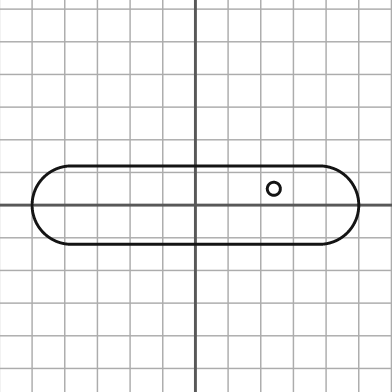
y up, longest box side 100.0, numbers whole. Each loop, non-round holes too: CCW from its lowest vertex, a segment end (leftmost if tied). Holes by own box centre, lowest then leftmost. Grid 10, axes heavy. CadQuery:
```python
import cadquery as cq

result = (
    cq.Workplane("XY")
    .moveTo(-38.0, -12.0)
    .lineTo(38.0, -12.0)
    .threePointArc((50.0, 0.0), (38.0, 12.0))
    .lineTo(-38.0, 12.0)
    .threePointArc((-50.0, 0.0), (-38.0, -12.0))
    .close()
    .moveTo(24.0, 5.0)
    .circle(2.0)
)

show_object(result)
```